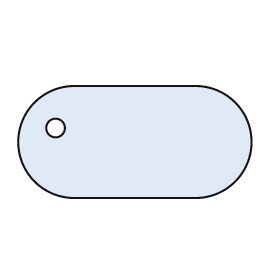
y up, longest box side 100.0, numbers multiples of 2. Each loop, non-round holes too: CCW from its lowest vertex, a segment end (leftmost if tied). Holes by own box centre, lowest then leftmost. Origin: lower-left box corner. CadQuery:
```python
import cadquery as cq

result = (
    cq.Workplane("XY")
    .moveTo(24.0, 0.0)
    .lineTo(76.0, 0.0)
    .threePointArc((100.0, 24.0), (76.0, 48.0))
    .lineTo(24.0, 48.0)
    .threePointArc((0.0, 24.0), (24.0, 0.0))
    .close()
    .moveTo(16.0, 30.0)
    .circle(4.0)
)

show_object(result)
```